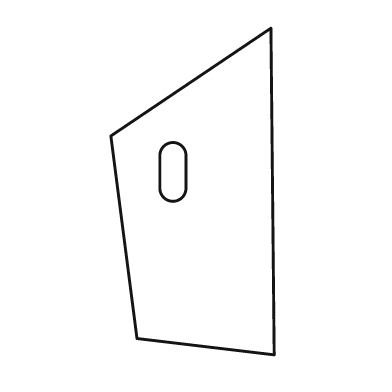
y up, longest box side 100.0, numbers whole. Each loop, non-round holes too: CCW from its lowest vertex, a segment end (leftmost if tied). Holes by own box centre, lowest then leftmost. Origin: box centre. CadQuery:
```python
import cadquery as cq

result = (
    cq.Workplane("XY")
    .moveTo(25.0, -50.0)
    .lineTo(24.0, 50.0)
    .lineTo(-25.0, 17.0)
    .lineTo(-17.0, -45.0)
    .close()
    .moveTo(-10.0, 1.0)
    .threePointArc((-6.0, -3.0), (-2.0, 1.0))
    .lineTo(-2.0, 11.0)
    .threePointArc((-6.0, 15.0), (-10.0, 11.0))
    .close()
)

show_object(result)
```